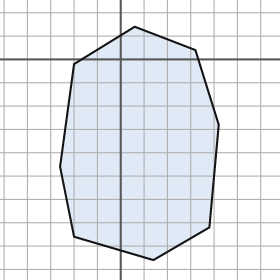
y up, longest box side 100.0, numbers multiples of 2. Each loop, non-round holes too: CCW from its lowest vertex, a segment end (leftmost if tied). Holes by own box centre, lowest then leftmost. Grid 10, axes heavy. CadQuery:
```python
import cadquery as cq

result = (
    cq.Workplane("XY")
    .moveTo(14.0, -86.0)
    .lineTo(38.0, -72.0)
    .lineTo(42.0, -28.0)
    .lineTo(32.0, 4.0)
    .lineTo(6.0, 14.0)
    .lineTo(-20.0, -2.0)
    .lineTo(-26.0, -46.0)
    .lineTo(-20.0, -76.0)
    .close()
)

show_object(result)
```